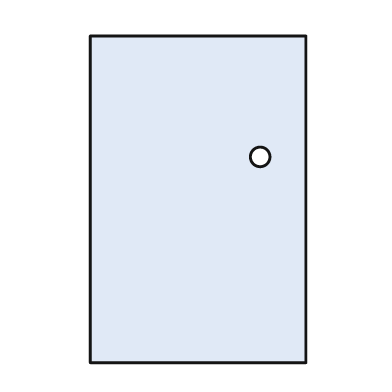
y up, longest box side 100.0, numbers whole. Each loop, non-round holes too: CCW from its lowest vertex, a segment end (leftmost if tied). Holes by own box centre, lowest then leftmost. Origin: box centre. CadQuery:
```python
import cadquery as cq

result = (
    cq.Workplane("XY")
    .moveTo(-33.0, -50.0)
    .lineTo(33.0, -50.0)
    .lineTo(33.0, 50.0)
    .lineTo(-33.0, 50.0)
    .close()
    .moveTo(19.0, 13.0)
    .circle(3.0)
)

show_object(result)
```